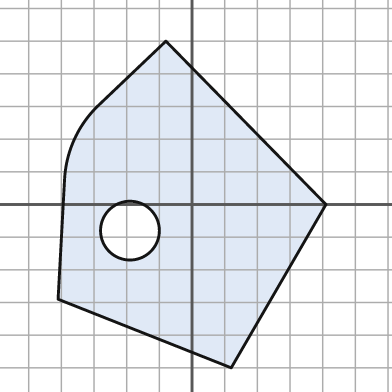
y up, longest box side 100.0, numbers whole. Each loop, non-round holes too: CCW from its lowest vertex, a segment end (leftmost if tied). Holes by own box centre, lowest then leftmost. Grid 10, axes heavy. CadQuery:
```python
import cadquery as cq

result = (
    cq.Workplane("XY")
    .moveTo(12.0, -50.0)
    .lineTo(41.0, 0.0)
    .lineTo(-8.0, 50.0)
    .lineTo(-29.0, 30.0)
    .threePointArc((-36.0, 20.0), (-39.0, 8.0))
    .lineTo(-41.0, -29.0)
    .close()
    .moveTo(-19.0, -8.0)
    .circle(9.0)
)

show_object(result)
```